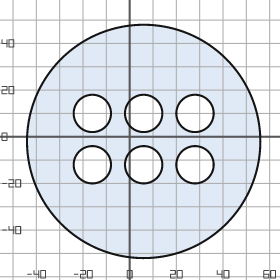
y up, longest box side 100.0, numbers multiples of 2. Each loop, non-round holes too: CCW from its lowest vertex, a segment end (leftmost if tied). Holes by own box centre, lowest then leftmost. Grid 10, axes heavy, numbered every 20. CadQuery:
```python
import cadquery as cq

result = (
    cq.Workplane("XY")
    .moveTo(6.0, -2.0)
    .circle(50.0)
    .moveTo(-16.0, -12.0)
    .circle(8.0)
    .moveTo(6.0, -12.0)
    .circle(8.0)
    .moveTo(28.0, -12.0)
    .circle(8.0)
    .moveTo(-16.0, 10.0)
    .circle(8.0)
    .moveTo(6.0, 10.0)
    .circle(8.0)
    .moveTo(28.0, 10.0)
    .circle(8.0)
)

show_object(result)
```